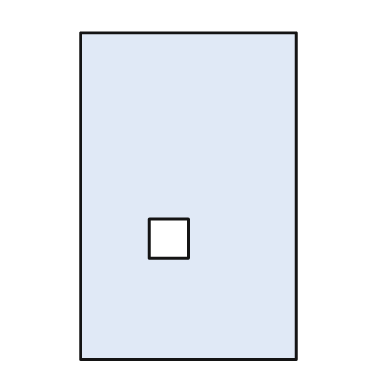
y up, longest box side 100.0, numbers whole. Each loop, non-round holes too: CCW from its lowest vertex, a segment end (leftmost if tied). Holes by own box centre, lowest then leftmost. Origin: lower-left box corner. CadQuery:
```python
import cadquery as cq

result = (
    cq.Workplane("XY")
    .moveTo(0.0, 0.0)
    .lineTo(66.0, 0.0)
    .lineTo(66.0, 100.0)
    .lineTo(0.0, 100.0)
    .close()
    .moveTo(21.0, 31.0)
    .lineTo(33.0, 31.0)
    .lineTo(33.0, 43.0)
    .lineTo(21.0, 43.0)
    .close()
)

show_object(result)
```